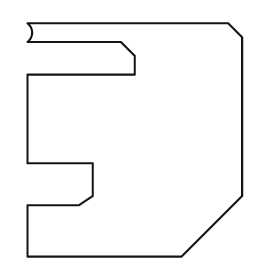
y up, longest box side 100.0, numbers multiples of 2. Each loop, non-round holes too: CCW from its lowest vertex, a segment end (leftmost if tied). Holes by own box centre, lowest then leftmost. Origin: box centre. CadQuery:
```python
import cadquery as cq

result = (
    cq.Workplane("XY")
    .moveTo(-46.0, -50.0)
    .lineTo(20.0, -50.0)
    .lineTo(46.0, -24.0)
    .lineTo(46.0, 44.0)
    .lineTo(40.0, 50.0)
    .lineTo(-46.0, 50.0)
    .threePointArc((-44.0, 46.0), (-46.0, 42.0))
    .lineTo(-6.0, 42.0)
    .lineTo(0.0, 36.0)
    .lineTo(0.0, 28.0)
    .lineTo(-46.0, 28.0)
    .lineTo(-46.0, -10.0)
    .lineTo(-18.0, -10.0)
    .lineTo(-18.0, -24.0)
    .lineTo(-24.0, -28.0)
    .lineTo(-46.0, -28.0)
    .close()
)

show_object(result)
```